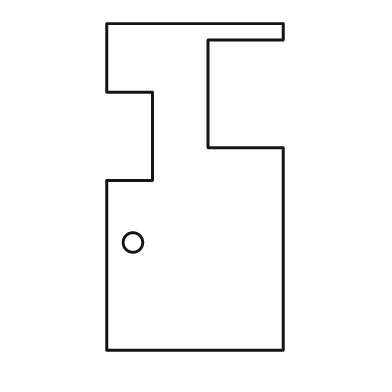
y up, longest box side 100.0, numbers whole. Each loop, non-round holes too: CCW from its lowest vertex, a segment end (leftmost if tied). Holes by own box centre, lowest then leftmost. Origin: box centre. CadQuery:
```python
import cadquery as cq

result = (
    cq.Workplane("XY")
    .moveTo(-27.0, -50.0)
    .lineTo(27.0, -50.0)
    .lineTo(27.0, 12.0)
    .lineTo(4.0, 12.0)
    .lineTo(4.0, 45.0)
    .lineTo(27.0, 45.0)
    .lineTo(27.0, 50.0)
    .lineTo(-27.0, 50.0)
    .lineTo(-27.0, 29.0)
    .lineTo(-13.0, 29.0)
    .lineTo(-13.0, 2.0)
    .lineTo(-27.0, 2.0)
    .close()
    .moveTo(-19.0, -17.0)
    .circle(3.0)
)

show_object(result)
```